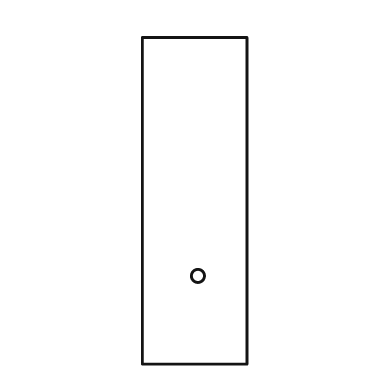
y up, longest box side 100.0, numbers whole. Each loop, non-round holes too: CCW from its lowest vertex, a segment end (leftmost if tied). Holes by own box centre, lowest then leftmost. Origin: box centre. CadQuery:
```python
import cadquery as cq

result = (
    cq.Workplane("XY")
    .moveTo(-16.0, -50.0)
    .lineTo(16.0, -50.0)
    .lineTo(16.0, 50.0)
    .lineTo(-16.0, 50.0)
    .close()
    .moveTo(1.0, -23.0)
    .circle(2.0)
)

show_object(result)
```